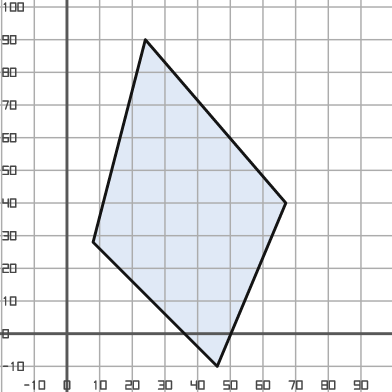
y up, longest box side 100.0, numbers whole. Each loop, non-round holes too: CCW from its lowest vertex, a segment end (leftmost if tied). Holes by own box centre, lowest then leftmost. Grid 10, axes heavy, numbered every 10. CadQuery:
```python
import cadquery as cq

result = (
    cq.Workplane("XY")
    .moveTo(46.0, -10.0)
    .lineTo(67.0, 40.0)
    .lineTo(24.0, 90.0)
    .lineTo(8.0, 28.0)
    .close()
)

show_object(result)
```